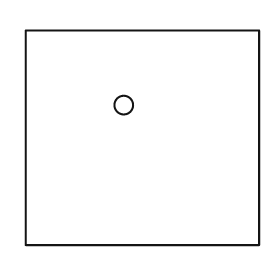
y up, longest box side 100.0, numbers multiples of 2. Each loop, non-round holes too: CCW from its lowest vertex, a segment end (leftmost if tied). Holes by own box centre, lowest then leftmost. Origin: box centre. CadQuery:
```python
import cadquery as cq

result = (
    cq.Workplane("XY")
    .moveTo(-50.0, -46.0)
    .lineTo(50.0, -46.0)
    .lineTo(50.0, 46.0)
    .lineTo(-50.0, 46.0)
    .close()
    .moveTo(-8.0, 14.0)
    .circle(4.0)
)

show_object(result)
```